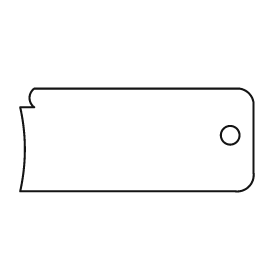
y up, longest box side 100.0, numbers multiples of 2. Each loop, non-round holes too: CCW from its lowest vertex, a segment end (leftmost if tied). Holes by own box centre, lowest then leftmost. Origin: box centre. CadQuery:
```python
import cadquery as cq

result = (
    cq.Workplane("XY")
    .moveTo(-50.0, -22.0)
    .lineTo(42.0, -22.0)
    .threePointArc((48.0, -20.0), (50.0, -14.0))
    .lineTo(50.0, 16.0)
    .threePointArc((48.0, 20.0), (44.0, 22.0))
    .lineTo(-44.0, 22.0)
    .threePointArc((-46.0, 18.0), (-44.0, 14.0))
    .lineTo(-50.0, 14.0)
    .threePointArc((-48.0, -4.0), (-50.0, -22.0))
    .close()
    .moveTo(40.0, 2.0)
    .circle(4.0)
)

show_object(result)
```